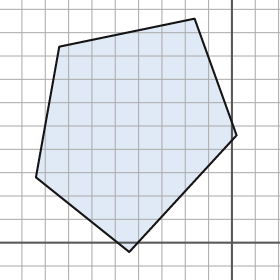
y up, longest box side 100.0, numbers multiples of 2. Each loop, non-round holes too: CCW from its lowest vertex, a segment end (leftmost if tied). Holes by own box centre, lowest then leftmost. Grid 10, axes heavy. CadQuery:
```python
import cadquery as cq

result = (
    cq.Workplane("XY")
    .moveTo(-44.0, -4.0)
    .lineTo(2.0, 46.0)
    .lineTo(-16.0, 96.0)
    .lineTo(-74.0, 84.0)
    .lineTo(-84.0, 28.0)
    .close()
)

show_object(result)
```